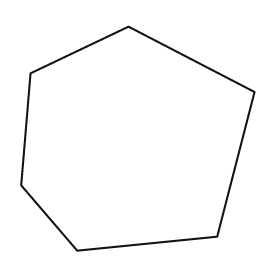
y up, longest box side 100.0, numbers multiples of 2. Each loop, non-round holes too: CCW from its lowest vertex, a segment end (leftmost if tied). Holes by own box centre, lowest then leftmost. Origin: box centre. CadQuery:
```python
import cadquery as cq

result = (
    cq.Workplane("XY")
    .moveTo(-26.0, -48.0)
    .lineTo(34.0, -42.0)
    .lineTo(50.0, 20.0)
    .lineTo(-4.0, 48.0)
    .lineTo(-46.0, 28.0)
    .lineTo(-50.0, -20.0)
    .close()
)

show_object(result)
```